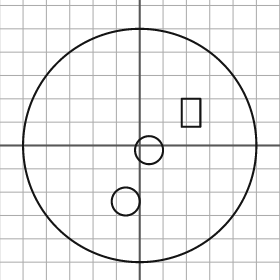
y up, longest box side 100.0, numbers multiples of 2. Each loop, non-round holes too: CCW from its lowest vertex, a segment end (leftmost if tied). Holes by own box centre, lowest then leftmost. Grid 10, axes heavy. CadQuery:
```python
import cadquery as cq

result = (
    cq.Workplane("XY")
    .moveTo(0.0, 0.0)
    .circle(50.0)
    .moveTo(-6.0, -24.0)
    .circle(6.0)
    .moveTo(4.0, -2.0)
    .circle(6.0)
    .moveTo(18.0, 8.0)
    .lineTo(26.0, 8.0)
    .lineTo(26.0, 20.0)
    .lineTo(18.0, 20.0)
    .close()
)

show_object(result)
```